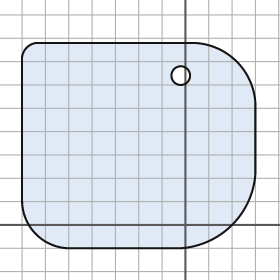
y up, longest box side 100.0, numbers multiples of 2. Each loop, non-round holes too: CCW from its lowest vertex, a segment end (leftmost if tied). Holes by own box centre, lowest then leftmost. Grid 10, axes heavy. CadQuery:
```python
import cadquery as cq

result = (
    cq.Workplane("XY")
    .moveTo(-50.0, -10.0)
    .lineTo(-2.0, -10.0)
    .threePointArc((20.0, 0.0), (30.0, 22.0))
    .lineTo(30.0, 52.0)
    .threePointArc((22.0, 70.0), (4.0, 78.0))
    .lineTo(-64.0, 78.0)
    .threePointArc((-68.0, 76.0), (-70.0, 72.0))
    .lineTo(-70.0, 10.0)
    .threePointArc((-64.0, -4.0), (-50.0, -10.0))
    .close()
    .moveTo(-2.0, 64.0)
    .circle(4.0)
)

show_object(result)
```